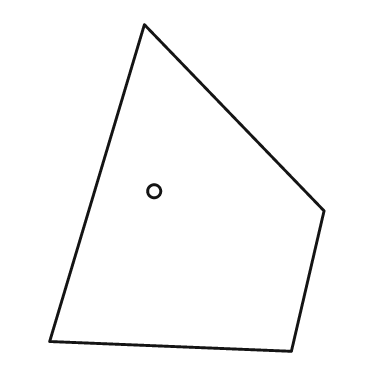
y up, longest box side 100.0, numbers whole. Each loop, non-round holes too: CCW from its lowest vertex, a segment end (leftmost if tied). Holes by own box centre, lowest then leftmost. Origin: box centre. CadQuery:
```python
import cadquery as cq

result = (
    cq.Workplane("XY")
    .moveTo(32.0, -50.0)
    .lineTo(42.0, -7.0)
    .lineTo(-13.0, 50.0)
    .lineTo(-42.0, -47.0)
    .close()
    .moveTo(-10.0, -1.0)
    .circle(2.0)
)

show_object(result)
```